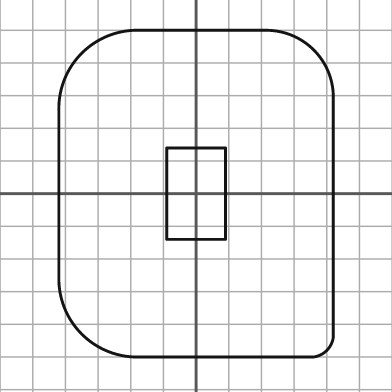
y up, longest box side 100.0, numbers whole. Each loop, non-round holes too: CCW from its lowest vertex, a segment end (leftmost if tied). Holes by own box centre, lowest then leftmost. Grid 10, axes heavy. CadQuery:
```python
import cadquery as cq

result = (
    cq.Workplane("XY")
    .moveTo(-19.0, -50.0)
    .lineTo(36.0, -50.0)
    .threePointArc((40.0, -48.0), (42.0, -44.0))
    .lineTo(42.0, 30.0)
    .threePointArc((36.0, 44.0), (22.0, 50.0))
    .lineTo(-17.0, 50.0)
    .threePointArc((-35.0, 43.0), (-42.0, 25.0))
    .lineTo(-42.0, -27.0)
    .threePointArc((-35.0, -43.0), (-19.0, -50.0))
    .close()
    .moveTo(-9.0, -14.0)
    .lineTo(9.0, -14.0)
    .lineTo(9.0, 14.0)
    .lineTo(-9.0, 14.0)
    .close()
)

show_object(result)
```